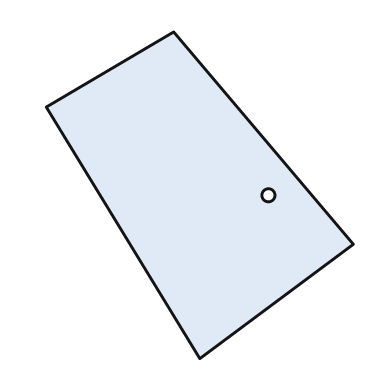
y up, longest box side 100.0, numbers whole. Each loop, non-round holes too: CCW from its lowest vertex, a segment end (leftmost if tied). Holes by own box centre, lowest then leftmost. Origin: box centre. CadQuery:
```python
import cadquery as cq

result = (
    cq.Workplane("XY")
    .moveTo(0.0, -50.0)
    .lineTo(47.0, -15.0)
    .lineTo(-8.0, 50.0)
    .lineTo(-47.0, 27.0)
    .close()
    .moveTo(21.0, 0.0)
    .circle(2.0)
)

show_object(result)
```